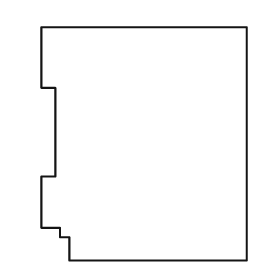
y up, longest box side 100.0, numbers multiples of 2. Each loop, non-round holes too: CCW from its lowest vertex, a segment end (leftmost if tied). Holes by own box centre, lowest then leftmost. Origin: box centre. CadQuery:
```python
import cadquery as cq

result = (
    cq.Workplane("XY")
    .moveTo(-32.0, -50.0)
    .lineTo(44.0, -50.0)
    .lineTo(44.0, 50.0)
    .lineTo(-44.0, 50.0)
    .lineTo(-44.0, 24.0)
    .lineTo(-38.0, 24.0)
    .lineTo(-38.0, -14.0)
    .lineTo(-44.0, -14.0)
    .lineTo(-44.0, -36.0)
    .lineTo(-36.0, -36.0)
    .lineTo(-36.0, -40.0)
    .lineTo(-32.0, -40.0)
    .close()
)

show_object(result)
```